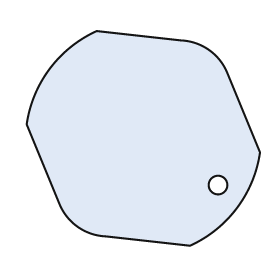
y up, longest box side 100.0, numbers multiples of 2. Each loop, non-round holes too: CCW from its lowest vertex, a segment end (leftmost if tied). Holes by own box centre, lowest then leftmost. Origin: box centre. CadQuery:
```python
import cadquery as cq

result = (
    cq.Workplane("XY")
    .moveTo(20.0, -46.0)
    .threePointArc((40.0, -30.0), (50.0, -6.0))
    .lineTo(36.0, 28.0)
    .threePointArc((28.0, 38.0), (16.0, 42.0))
    .lineTo(-20.0, 46.0)
    .threePointArc((-40.0, 30.0), (-50.0, 6.0))
    .lineTo(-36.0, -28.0)
    .threePointArc((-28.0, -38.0), (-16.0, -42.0))
    .close()
    .moveTo(32.0, -20.0)
    .circle(4.0)
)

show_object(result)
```